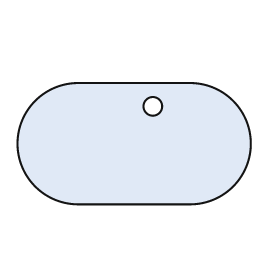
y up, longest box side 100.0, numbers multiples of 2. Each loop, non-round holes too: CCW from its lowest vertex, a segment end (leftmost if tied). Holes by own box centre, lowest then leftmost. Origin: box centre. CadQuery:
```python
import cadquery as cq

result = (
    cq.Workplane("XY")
    .moveTo(-24.0, -26.0)
    .lineTo(24.0, -26.0)
    .threePointArc((50.0, 0.0), (24.0, 26.0))
    .lineTo(-24.0, 26.0)
    .threePointArc((-50.0, 0.0), (-24.0, -26.0))
    .close()
    .moveTo(8.0, 16.0)
    .circle(4.0)
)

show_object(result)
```